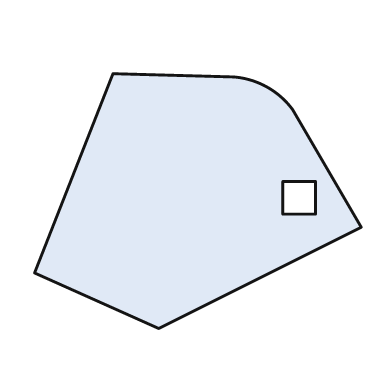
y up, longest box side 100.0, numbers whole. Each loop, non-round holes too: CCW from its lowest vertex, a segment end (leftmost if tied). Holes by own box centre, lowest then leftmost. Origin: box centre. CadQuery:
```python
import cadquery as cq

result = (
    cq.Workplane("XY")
    .moveTo(-12.0, -39.0)
    .lineTo(50.0, -8.0)
    .lineTo(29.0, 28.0)
    .threePointArc((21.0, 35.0), (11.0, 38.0))
    .lineTo(-26.0, 39.0)
    .lineTo(-50.0, -22.0)
    .close()
    .moveTo(26.0, -4.0)
    .lineTo(36.0, -4.0)
    .lineTo(36.0, 6.0)
    .lineTo(26.0, 6.0)
    .close()
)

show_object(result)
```